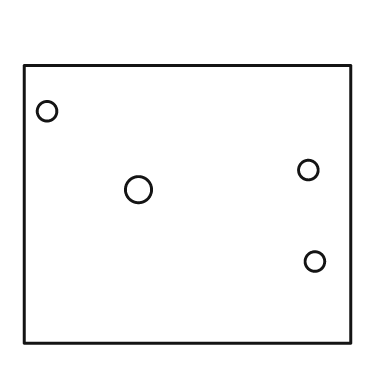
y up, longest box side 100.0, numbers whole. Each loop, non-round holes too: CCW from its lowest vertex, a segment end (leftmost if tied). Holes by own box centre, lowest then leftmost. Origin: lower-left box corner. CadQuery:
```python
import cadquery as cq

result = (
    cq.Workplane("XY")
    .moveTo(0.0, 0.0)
    .lineTo(100.0, 0.0)
    .lineTo(100.0, 85.0)
    .lineTo(0.0, 85.0)
    .close()
    .moveTo(89.0, 25.0)
    .circle(3.0)
    .moveTo(35.0, 47.0)
    .circle(4.0)
    .moveTo(87.0, 53.0)
    .circle(3.0)
    .moveTo(7.0, 71.0)
    .circle(3.0)
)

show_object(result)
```